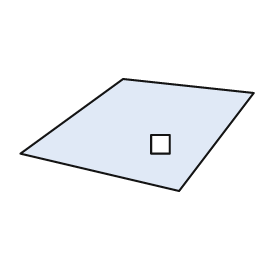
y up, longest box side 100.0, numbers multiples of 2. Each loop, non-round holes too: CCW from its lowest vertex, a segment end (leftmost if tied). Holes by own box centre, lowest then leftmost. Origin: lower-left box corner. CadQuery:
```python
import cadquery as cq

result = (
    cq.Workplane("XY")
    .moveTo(68.0, 0.0)
    .lineTo(100.0, 42.0)
    .lineTo(44.0, 48.0)
    .lineTo(0.0, 16.0)
    .close()
    .moveTo(56.0, 16.0)
    .lineTo(64.0, 16.0)
    .lineTo(64.0, 24.0)
    .lineTo(56.0, 24.0)
    .close()
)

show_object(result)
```